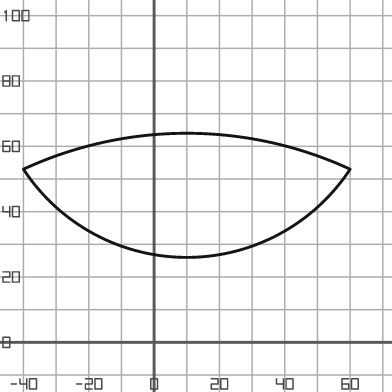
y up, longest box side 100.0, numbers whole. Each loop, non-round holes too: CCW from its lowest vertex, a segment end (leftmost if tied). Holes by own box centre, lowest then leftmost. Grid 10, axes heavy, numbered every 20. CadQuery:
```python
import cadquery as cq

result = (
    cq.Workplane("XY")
    .moveTo(-40.0, 53.0)
    .threePointArc((10.0, 26.0), (60.0, 53.0))
    .threePointArc((10.0, 64.0), (-40.0, 53.0))
    .close()
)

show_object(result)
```